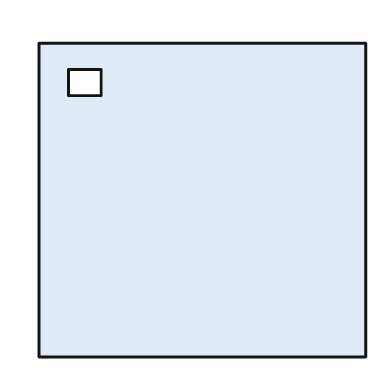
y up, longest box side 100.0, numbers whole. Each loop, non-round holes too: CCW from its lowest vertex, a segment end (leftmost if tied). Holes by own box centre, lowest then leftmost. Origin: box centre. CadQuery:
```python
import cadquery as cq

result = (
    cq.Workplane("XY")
    .moveTo(-50.0, -48.0)
    .lineTo(50.0, -48.0)
    .lineTo(50.0, 48.0)
    .lineTo(-50.0, 48.0)
    .close()
    .moveTo(-41.0, 32.0)
    .lineTo(-31.0, 32.0)
    .lineTo(-31.0, 40.0)
    .lineTo(-41.0, 40.0)
    .close()
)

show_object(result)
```